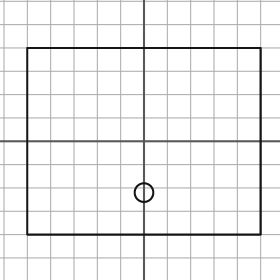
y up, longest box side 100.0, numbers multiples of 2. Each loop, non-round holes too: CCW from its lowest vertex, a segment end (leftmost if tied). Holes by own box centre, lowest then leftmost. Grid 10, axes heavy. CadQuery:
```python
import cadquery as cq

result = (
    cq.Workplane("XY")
    .moveTo(-50.0, -40.0)
    .lineTo(50.0, -40.0)
    .lineTo(50.0, 40.0)
    .lineTo(-50.0, 40.0)
    .close()
    .moveTo(0.0, -22.0)
    .circle(4.0)
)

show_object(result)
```